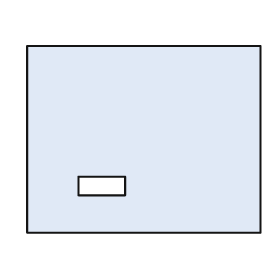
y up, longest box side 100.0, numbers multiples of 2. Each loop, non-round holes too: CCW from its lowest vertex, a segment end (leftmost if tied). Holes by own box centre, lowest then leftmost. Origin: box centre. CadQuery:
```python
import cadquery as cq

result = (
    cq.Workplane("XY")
    .moveTo(-50.0, -40.0)
    .lineTo(50.0, -40.0)
    .lineTo(50.0, 40.0)
    .lineTo(-50.0, 40.0)
    .close()
    .moveTo(-28.0, -24.0)
    .lineTo(-8.0, -24.0)
    .lineTo(-8.0, -16.0)
    .lineTo(-28.0, -16.0)
    .close()
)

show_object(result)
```